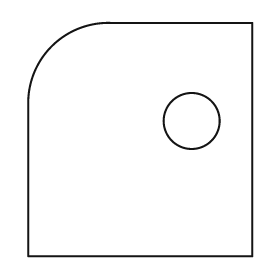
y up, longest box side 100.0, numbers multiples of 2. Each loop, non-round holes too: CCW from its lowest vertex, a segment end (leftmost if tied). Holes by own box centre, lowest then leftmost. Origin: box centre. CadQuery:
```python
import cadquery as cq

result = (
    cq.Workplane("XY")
    .moveTo(-48.0, -50.0)
    .lineTo(48.0, -50.0)
    .lineTo(48.0, 50.0)
    .lineTo(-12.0, 50.0)
    .threePointArc((-38.0, 40.0), (-48.0, 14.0))
    .close()
    .moveTo(22.0, 8.0)
    .circle(12.0)
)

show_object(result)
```